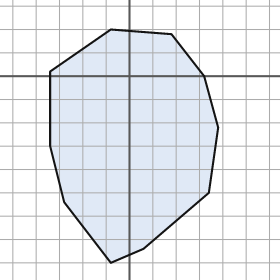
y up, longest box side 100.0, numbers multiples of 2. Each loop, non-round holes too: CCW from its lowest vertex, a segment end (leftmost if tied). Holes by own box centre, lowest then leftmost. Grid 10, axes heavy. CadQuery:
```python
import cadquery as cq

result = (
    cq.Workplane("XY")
    .moveTo(-8.0, -80.0)
    .lineTo(6.0, -74.0)
    .lineTo(34.0, -50.0)
    .lineTo(38.0, -22.0)
    .lineTo(32.0, 0.0)
    .lineTo(18.0, 18.0)
    .lineTo(-8.0, 20.0)
    .lineTo(-34.0, 2.0)
    .lineTo(-34.0, -30.0)
    .lineTo(-28.0, -54.0)
    .close()
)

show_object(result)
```